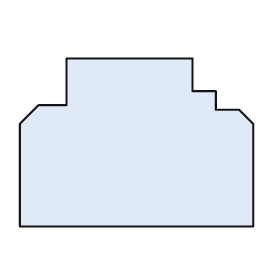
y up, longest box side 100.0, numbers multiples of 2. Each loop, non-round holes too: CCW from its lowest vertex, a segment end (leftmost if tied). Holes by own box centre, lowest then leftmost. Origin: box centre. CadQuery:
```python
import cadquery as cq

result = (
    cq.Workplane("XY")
    .moveTo(-50.0, -36.0)
    .lineTo(50.0, -36.0)
    .lineTo(50.0, 8.0)
    .lineTo(44.0, 14.0)
    .lineTo(34.0, 14.0)
    .lineTo(34.0, 22.0)
    .lineTo(24.0, 22.0)
    .lineTo(24.0, 36.0)
    .lineTo(-30.0, 36.0)
    .lineTo(-30.0, 16.0)
    .lineTo(-42.0, 16.0)
    .lineTo(-50.0, 8.0)
    .close()
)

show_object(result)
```